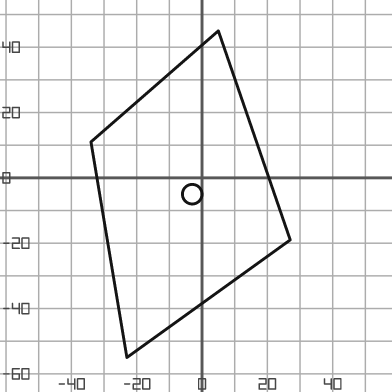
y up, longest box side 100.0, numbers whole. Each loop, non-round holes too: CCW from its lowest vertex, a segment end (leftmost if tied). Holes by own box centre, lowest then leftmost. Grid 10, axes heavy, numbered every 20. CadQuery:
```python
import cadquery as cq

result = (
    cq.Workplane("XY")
    .moveTo(-23.0, -55.0)
    .lineTo(27.0, -19.0)
    .lineTo(5.0, 45.0)
    .lineTo(-34.0, 11.0)
    .close()
    .moveTo(-3.0, -5.0)
    .circle(3.0)
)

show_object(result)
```